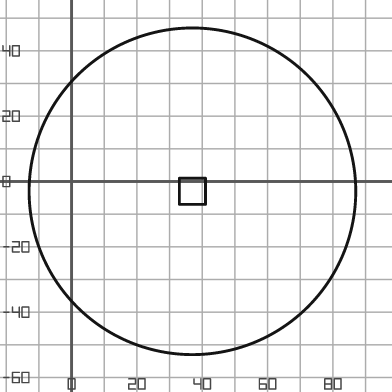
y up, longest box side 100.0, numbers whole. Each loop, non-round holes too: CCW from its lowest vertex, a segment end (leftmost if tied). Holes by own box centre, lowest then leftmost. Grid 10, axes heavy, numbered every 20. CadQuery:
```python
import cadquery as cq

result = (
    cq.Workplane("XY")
    .moveTo(37.0, -3.0)
    .circle(50.0)
    .moveTo(33.0, -7.0)
    .lineTo(41.0, -7.0)
    .lineTo(41.0, 1.0)
    .lineTo(33.0, 1.0)
    .close()
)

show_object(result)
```